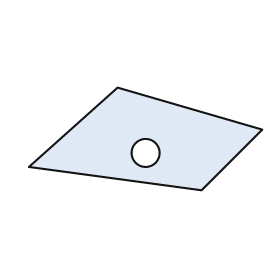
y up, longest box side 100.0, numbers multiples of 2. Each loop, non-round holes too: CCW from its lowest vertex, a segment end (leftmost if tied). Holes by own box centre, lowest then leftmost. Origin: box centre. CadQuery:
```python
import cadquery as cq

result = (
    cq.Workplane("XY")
    .moveTo(24.0, -22.0)
    .lineTo(50.0, 4.0)
    .lineTo(-12.0, 22.0)
    .lineTo(-50.0, -12.0)
    .close()
    .moveTo(0.0, -6.0)
    .circle(6.0)
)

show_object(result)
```